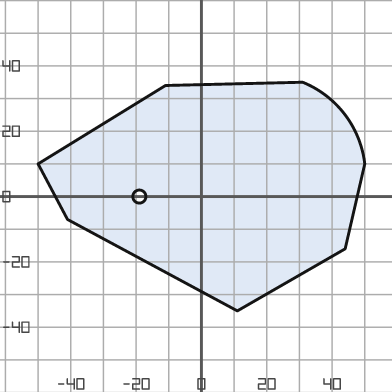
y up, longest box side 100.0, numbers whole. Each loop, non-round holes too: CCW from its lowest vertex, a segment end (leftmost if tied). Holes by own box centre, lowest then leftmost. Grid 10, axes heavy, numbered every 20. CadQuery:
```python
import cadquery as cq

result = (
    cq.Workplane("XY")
    .moveTo(11.0, -35.0)
    .lineTo(44.0, -16.0)
    .lineTo(50.0, 10.0)
    .threePointArc((44.0, 25.0), (31.0, 35.0))
    .lineTo(-11.0, 34.0)
    .lineTo(-50.0, 10.0)
    .lineTo(-41.0, -7.0)
    .close()
    .moveTo(-19.0, 0.0)
    .circle(2.0)
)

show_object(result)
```